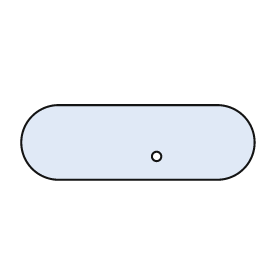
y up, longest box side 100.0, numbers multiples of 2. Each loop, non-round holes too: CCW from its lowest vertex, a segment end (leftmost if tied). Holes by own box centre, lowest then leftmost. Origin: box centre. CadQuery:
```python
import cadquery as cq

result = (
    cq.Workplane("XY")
    .moveTo(-34.0, -16.0)
    .lineTo(34.0, -16.0)
    .threePointArc((50.0, 0.0), (34.0, 16.0))
    .lineTo(-34.0, 16.0)
    .threePointArc((-50.0, 0.0), (-34.0, -16.0))
    .close()
    .moveTo(8.0, -6.0)
    .circle(2.0)
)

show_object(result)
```